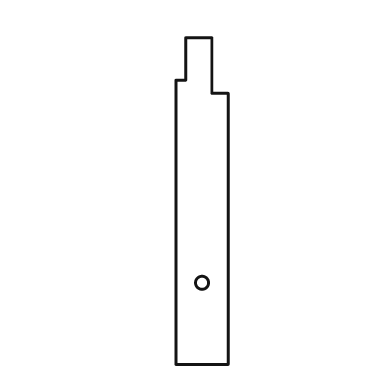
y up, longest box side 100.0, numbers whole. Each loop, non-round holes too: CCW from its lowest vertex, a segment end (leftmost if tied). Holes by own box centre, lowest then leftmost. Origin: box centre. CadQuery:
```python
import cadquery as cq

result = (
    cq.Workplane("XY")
    .moveTo(-8.0, -50.0)
    .lineTo(8.0, -50.0)
    .lineTo(8.0, 33.0)
    .lineTo(3.0, 33.0)
    .lineTo(3.0, 50.0)
    .lineTo(-5.0, 50.0)
    .lineTo(-5.0, 37.0)
    .lineTo(-8.0, 37.0)
    .close()
    .moveTo(0.0, -25.0)
    .circle(2.0)
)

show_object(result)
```